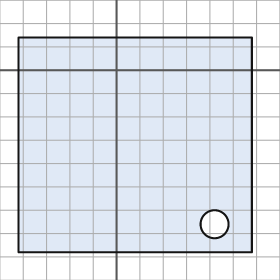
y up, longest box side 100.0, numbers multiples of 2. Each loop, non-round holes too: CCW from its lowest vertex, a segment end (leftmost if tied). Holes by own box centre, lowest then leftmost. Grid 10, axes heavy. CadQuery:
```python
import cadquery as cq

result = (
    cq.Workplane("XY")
    .moveTo(-42.0, -78.0)
    .lineTo(58.0, -78.0)
    .lineTo(58.0, 14.0)
    .lineTo(-42.0, 14.0)
    .close()
    .moveTo(42.0, -66.0)
    .circle(6.0)
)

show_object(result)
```